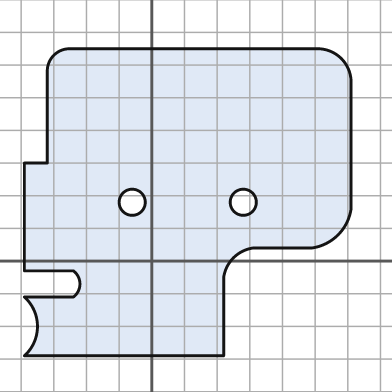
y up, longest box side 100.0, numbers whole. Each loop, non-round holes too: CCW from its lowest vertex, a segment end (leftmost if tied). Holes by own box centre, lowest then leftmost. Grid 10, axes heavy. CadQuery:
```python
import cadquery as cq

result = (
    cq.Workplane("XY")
    .moveTo(-39.0, -29.0)
    .lineTo(22.0, -29.0)
    .lineTo(22.0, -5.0)
    .threePointArc((25.0, 1.0), (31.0, 4.0))
    .lineTo(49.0, 4.0)
    .threePointArc((57.0, 8.0), (61.0, 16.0))
    .lineTo(61.0, 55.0)
    .threePointArc((58.0, 62.0), (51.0, 65.0))
    .lineTo(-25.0, 65.0)
    .threePointArc((-30.0, 63.0), (-32.0, 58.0))
    .lineTo(-32.0, 30.0)
    .lineTo(-39.0, 30.0)
    .lineTo(-39.0, -3.0)
    .lineTo(-24.0, -3.0)
    .threePointArc((-22.0, -7.0), (-24.0, -11.0))
    .lineTo(-39.0, -11.0)
    .threePointArc((-35.0, -20.0), (-39.0, -29.0))
    .close()
    .moveTo(-6.0, 18.0)
    .circle(4.0)
    .moveTo(28.0, 18.0)
    .circle(4.0)
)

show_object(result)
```